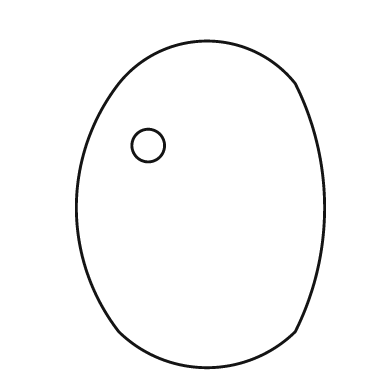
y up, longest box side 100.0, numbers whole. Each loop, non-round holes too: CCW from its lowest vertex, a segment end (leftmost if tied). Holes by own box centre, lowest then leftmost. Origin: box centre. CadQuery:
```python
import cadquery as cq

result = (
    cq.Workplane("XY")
    .moveTo(-25.0, -39.0)
    .threePointArc((2.0, -50.0), (29.0, -39.0))
    .threePointArc((38.0, -1.0), (29.0, 37.0))
    .threePointArc((2.0, 50.0), (-25.0, 37.0))
    .threePointArc((-38.0, -1.0), (-25.0, -39.0))
    .close()
    .moveTo(-16.0, 18.0)
    .circle(5.0)
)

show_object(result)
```